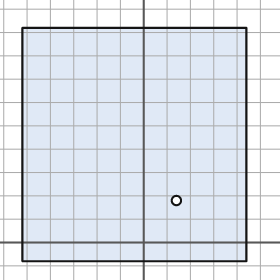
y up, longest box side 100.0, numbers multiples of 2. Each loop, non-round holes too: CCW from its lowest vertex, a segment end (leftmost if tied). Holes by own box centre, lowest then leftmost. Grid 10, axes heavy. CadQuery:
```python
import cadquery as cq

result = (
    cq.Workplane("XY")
    .moveTo(-52.0, -8.0)
    .lineTo(44.0, -8.0)
    .lineTo(44.0, 92.0)
    .lineTo(-52.0, 92.0)
    .close()
    .moveTo(14.0, 18.0)
    .circle(2.0)
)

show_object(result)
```